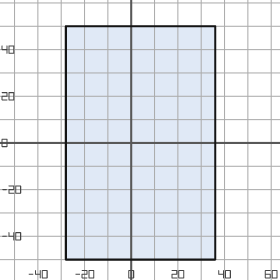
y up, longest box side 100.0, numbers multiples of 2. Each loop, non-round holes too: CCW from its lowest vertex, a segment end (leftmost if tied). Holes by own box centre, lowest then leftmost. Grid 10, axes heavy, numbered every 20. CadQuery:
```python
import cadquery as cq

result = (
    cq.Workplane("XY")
    .moveTo(-28.0, -50.0)
    .lineTo(36.0, -50.0)
    .lineTo(36.0, 50.0)
    .lineTo(-28.0, 50.0)
    .close()
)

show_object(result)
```